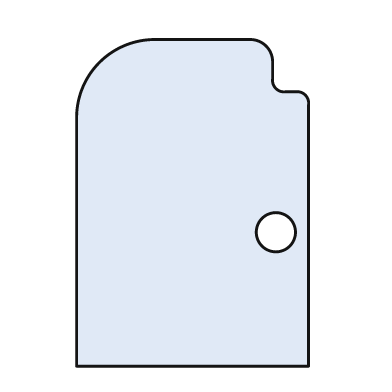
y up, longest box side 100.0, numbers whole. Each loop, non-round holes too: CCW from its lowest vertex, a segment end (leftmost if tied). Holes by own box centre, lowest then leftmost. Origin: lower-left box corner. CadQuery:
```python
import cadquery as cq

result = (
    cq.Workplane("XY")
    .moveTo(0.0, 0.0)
    .lineTo(71.0, 0.0)
    .lineTo(71.0, 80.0)
    .threePointArc((70.0, 83.0), (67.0, 84.0))
    .lineTo(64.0, 84.0)
    .threePointArc((61.0, 85.0), (60.0, 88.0))
    .lineTo(60.0, 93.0)
    .threePointArc((58.0, 98.0), (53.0, 100.0))
    .lineTo(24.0, 100.0)
    .threePointArc((7.0, 93.0), (0.0, 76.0))
    .close()
    .moveTo(61.0, 41.0)
    .circle(6.0)
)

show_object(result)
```